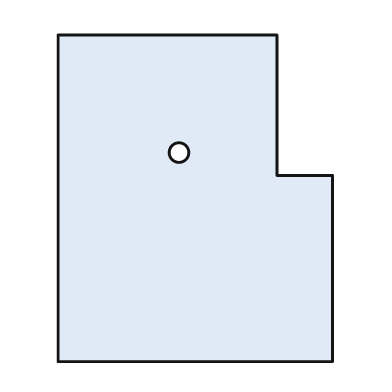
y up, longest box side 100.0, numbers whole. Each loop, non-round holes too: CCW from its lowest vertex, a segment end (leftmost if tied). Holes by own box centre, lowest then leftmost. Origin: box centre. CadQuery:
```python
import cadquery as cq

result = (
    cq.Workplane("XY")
    .moveTo(-42.0, -50.0)
    .lineTo(42.0, -50.0)
    .lineTo(42.0, 7.0)
    .lineTo(25.0, 7.0)
    .lineTo(25.0, 50.0)
    .lineTo(-42.0, 50.0)
    .close()
    .moveTo(-5.0, 14.0)
    .circle(3.0)
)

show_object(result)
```